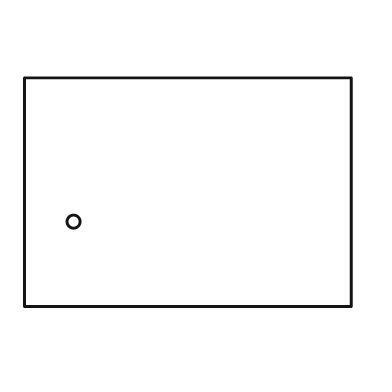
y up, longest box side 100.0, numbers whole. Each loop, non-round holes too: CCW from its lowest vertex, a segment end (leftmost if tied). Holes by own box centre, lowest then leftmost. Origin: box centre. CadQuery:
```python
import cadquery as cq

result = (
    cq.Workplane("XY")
    .moveTo(-50.0, -35.0)
    .lineTo(50.0, -35.0)
    .lineTo(50.0, 35.0)
    .lineTo(-50.0, 35.0)
    .close()
    .moveTo(-35.0, -9.0)
    .circle(2.0)
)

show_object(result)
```